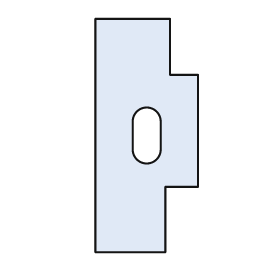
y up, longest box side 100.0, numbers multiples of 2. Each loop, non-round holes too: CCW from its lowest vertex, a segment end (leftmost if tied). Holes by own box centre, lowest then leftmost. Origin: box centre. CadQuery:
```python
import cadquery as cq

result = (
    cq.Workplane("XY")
    .moveTo(-22.0, -50.0)
    .lineTo(8.0, -50.0)
    .lineTo(8.0, -22.0)
    .lineTo(22.0, -22.0)
    .lineTo(22.0, 26.0)
    .lineTo(10.0, 26.0)
    .lineTo(10.0, 50.0)
    .lineTo(-22.0, 50.0)
    .close()
    .moveTo(-6.0, -6.0)
    .threePointArc((0.0, -12.0), (6.0, -6.0))
    .lineTo(6.0, 6.0)
    .threePointArc((0.0, 12.0), (-6.0, 6.0))
    .close()
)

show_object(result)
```